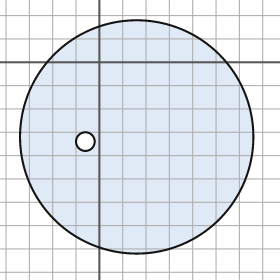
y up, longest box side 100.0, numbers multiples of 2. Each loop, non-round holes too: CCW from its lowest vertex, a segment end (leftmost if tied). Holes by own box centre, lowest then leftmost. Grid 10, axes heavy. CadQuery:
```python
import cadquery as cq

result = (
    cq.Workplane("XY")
    .moveTo(16.0, -32.0)
    .circle(50.0)
    .moveTo(-6.0, -34.0)
    .circle(4.0)
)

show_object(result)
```